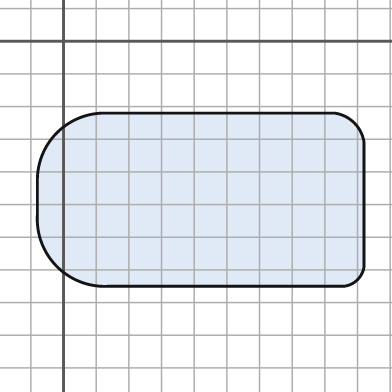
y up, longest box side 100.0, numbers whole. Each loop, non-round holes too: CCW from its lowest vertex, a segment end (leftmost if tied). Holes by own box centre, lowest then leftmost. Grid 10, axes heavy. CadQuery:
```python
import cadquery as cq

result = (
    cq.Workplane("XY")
    .moveTo(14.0, -75.0)
    .lineTo(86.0, -75.0)
    .threePointArc((90.0, -73.0), (92.0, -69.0))
    .lineTo(92.0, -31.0)
    .threePointArc((89.0, -25.0), (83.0, -22.0))
    .lineTo(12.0, -22.0)
    .threePointArc((-2.0, -28.0), (-8.0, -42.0))
    .lineTo(-8.0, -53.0)
    .threePointArc((-2.0, -69.0), (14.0, -75.0))
    .close()
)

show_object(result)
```